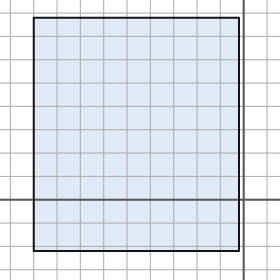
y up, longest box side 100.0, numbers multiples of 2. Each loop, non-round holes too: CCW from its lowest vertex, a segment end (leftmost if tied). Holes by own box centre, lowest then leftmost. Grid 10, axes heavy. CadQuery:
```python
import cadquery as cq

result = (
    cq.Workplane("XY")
    .moveTo(-90.0, -22.0)
    .lineTo(-2.0, -22.0)
    .lineTo(-2.0, 78.0)
    .lineTo(-90.0, 78.0)
    .close()
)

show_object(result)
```